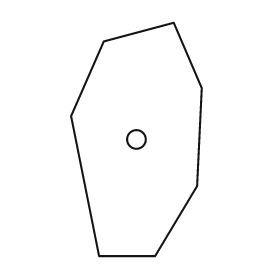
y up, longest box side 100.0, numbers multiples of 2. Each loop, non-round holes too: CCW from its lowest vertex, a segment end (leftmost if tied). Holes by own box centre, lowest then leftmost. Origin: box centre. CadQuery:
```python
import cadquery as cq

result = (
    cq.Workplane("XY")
    .moveTo(-16.0, -50.0)
    .lineTo(8.0, -50.0)
    .lineTo(26.0, -20.0)
    .lineTo(28.0, 22.0)
    .lineTo(16.0, 50.0)
    .lineTo(-14.0, 42.0)
    .lineTo(-28.0, 10.0)
    .close()
    .moveTo(0.0, 0.0)
    .circle(4.0)
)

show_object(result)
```